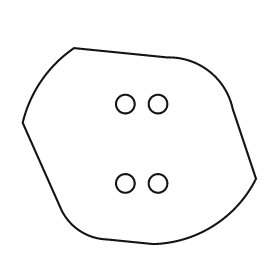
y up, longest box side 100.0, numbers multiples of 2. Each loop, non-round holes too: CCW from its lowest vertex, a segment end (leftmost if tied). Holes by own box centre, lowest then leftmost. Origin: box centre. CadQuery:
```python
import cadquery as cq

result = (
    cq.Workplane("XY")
    .moveTo(6.0, -42.0)
    .threePointArc((32.0, -34.0), (50.0, -14.0))
    .lineTo(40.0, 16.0)
    .threePointArc((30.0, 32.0), (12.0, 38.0))
    .lineTo(-28.0, 42.0)
    .threePointArc((-42.0, 28.0), (-50.0, 10.0))
    .lineTo(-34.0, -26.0)
    .threePointArc((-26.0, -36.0), (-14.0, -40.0))
    .close()
    .moveTo(-6.0, -16.0)
    .circle(4.0)
    .moveTo(8.0, -16.0)
    .circle(4.0)
    .moveTo(-6.0, 18.0)
    .circle(4.0)
    .moveTo(8.0, 18.0)
    .circle(4.0)
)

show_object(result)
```